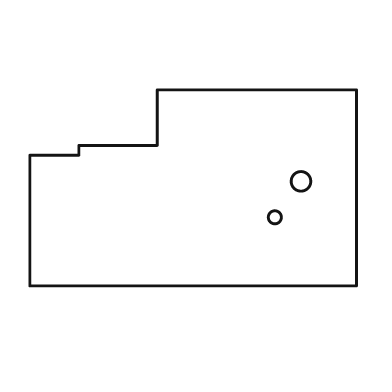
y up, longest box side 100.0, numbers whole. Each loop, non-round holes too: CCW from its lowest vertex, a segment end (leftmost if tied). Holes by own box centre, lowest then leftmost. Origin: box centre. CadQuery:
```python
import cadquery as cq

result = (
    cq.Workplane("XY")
    .moveTo(-50.0, -30.0)
    .lineTo(50.0, -30.0)
    .lineTo(50.0, 30.0)
    .lineTo(-11.0, 30.0)
    .lineTo(-11.0, 13.0)
    .lineTo(-35.0, 13.0)
    .lineTo(-35.0, 10.0)
    .lineTo(-50.0, 10.0)
    .close()
    .moveTo(25.0, -9.0)
    .circle(2.0)
    .moveTo(33.0, 2.0)
    .circle(3.0)
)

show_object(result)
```